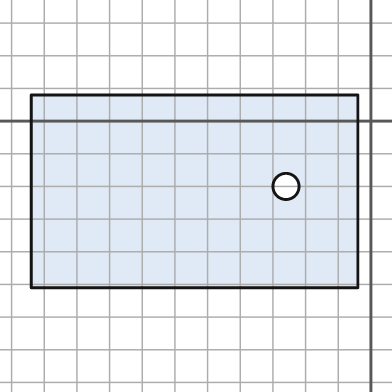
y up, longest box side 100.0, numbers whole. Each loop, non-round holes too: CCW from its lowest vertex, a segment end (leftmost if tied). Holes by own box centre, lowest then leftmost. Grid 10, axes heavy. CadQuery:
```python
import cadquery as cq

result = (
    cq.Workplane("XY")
    .moveTo(-104.0, -51.0)
    .lineTo(-4.0, -51.0)
    .lineTo(-4.0, 8.0)
    .lineTo(-104.0, 8.0)
    .close()
    .moveTo(-26.0, -20.0)
    .circle(4.0)
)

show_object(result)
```